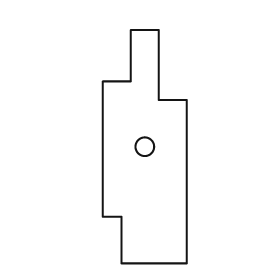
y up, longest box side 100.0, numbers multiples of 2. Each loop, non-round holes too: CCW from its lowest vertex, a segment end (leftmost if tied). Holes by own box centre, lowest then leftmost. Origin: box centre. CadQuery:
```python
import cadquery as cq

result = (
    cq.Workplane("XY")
    .moveTo(-10.0, -50.0)
    .lineTo(18.0, -50.0)
    .lineTo(18.0, 20.0)
    .lineTo(6.0, 20.0)
    .lineTo(6.0, 50.0)
    .lineTo(-6.0, 50.0)
    .lineTo(-6.0, 28.0)
    .lineTo(-18.0, 28.0)
    .lineTo(-18.0, -30.0)
    .lineTo(-10.0, -30.0)
    .close()
    .moveTo(0.0, 0.0)
    .circle(4.0)
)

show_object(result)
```